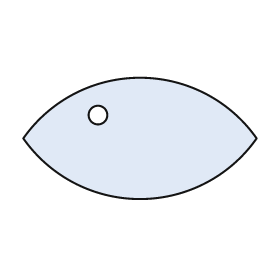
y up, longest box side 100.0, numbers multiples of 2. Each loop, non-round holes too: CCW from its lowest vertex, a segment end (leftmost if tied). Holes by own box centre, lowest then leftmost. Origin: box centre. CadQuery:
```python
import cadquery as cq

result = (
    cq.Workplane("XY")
    .moveTo(-50.0, 0.0)
    .threePointArc((0.0, -26.0), (50.0, 0.0))
    .threePointArc((0.0, 26.0), (-50.0, 0.0))
    .close()
    .moveTo(-18.0, 10.0)
    .circle(4.0)
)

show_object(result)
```